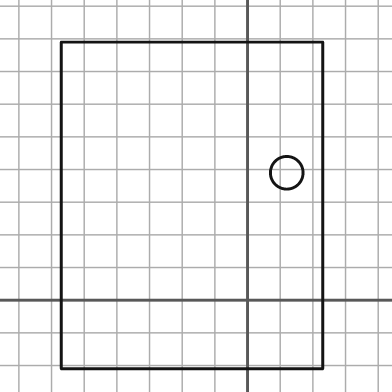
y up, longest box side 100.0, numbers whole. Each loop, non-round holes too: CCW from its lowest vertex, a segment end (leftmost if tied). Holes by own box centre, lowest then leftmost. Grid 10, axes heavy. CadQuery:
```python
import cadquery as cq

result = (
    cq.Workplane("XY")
    .moveTo(-57.0, -21.0)
    .lineTo(23.0, -21.0)
    .lineTo(23.0, 79.0)
    .lineTo(-57.0, 79.0)
    .close()
    .moveTo(12.0, 39.0)
    .circle(5.0)
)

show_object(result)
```